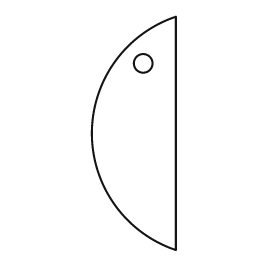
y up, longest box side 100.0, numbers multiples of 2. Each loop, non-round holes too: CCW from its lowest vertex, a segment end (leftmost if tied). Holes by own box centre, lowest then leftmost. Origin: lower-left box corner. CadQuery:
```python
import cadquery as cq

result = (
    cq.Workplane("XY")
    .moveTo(36.0, 0.0)
    .lineTo(36.0, 100.0)
    .threePointArc((0.0, 50.0), (36.0, 0.0))
    .close()
    .moveTo(22.0, 80.0)
    .circle(4.0)
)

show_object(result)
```